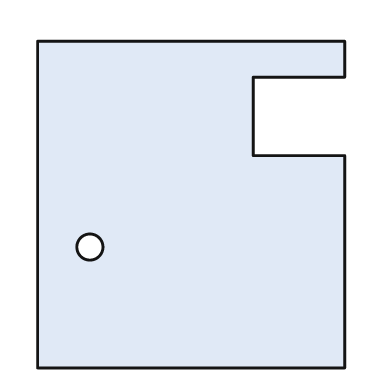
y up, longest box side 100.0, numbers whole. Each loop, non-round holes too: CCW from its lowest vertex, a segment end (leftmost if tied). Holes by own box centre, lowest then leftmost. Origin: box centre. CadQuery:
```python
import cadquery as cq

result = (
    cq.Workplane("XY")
    .moveTo(-47.0, -50.0)
    .lineTo(47.0, -50.0)
    .lineTo(47.0, 15.0)
    .lineTo(19.0, 15.0)
    .lineTo(19.0, 39.0)
    .lineTo(47.0, 39.0)
    .lineTo(47.0, 50.0)
    .lineTo(-47.0, 50.0)
    .close()
    .moveTo(-31.0, -13.0)
    .circle(4.0)
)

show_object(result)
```